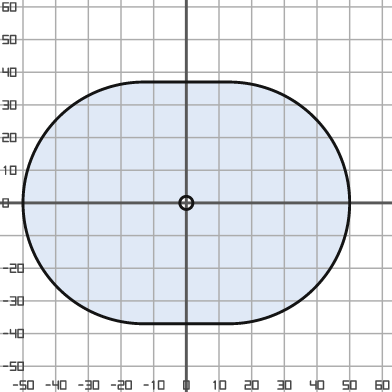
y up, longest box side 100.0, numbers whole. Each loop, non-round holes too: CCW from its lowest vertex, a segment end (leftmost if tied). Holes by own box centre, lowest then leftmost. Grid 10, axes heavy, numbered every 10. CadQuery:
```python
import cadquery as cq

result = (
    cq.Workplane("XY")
    .moveTo(-13.0, -37.0)
    .lineTo(13.0, -37.0)
    .threePointArc((50.0, 0.0), (13.0, 37.0))
    .lineTo(-13.0, 37.0)
    .threePointArc((-50.0, 0.0), (-13.0, -37.0))
    .close()
    .moveTo(0.0, 0.0)
    .circle(2.0)
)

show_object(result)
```